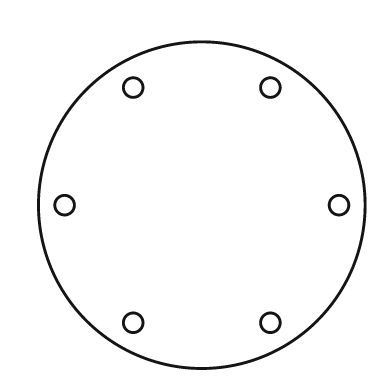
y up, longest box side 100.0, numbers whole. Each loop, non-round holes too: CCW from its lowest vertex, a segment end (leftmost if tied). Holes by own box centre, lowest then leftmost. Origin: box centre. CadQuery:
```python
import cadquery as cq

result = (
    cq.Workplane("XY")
    .moveTo(0.0, 0.0)
    .circle(50.0)
    .moveTo(-21.0, -36.0)
    .circle(3.0)
    .moveTo(21.0, -36.0)
    .circle(3.0)
    .moveTo(-42.0, 0.0)
    .circle(3.0)
    .moveTo(42.0, 0.0)
    .circle(3.0)
    .moveTo(-21.0, 36.0)
    .circle(3.0)
    .moveTo(21.0, 36.0)
    .circle(3.0)
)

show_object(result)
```